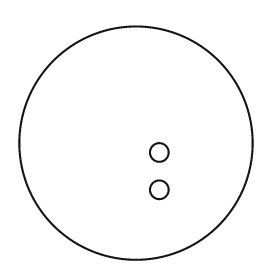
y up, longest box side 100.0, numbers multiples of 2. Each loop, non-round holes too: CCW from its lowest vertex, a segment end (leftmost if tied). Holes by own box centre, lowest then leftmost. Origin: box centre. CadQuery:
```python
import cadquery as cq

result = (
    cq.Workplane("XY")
    .moveTo(0.0, 0.0)
    .circle(50.0)
    .moveTo(10.0, -20.0)
    .circle(4.0)
    .moveTo(10.0, -4.0)
    .circle(4.0)
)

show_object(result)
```